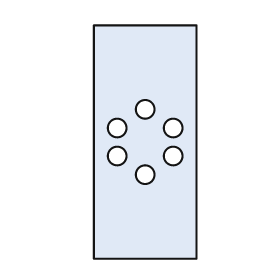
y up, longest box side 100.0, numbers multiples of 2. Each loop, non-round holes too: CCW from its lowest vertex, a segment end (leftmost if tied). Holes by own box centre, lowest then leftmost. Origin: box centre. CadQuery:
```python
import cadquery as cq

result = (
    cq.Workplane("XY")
    .moveTo(-22.0, -50.0)
    .lineTo(22.0, -50.0)
    .lineTo(22.0, 50.0)
    .lineTo(-22.0, 50.0)
    .close()
    .moveTo(0.0, -14.0)
    .circle(4.0)
    .moveTo(-12.0, -6.0)
    .circle(4.0)
    .moveTo(12.0, -6.0)
    .circle(4.0)
    .moveTo(-12.0, 6.0)
    .circle(4.0)
    .moveTo(12.0, 6.0)
    .circle(4.0)
    .moveTo(0.0, 14.0)
    .circle(4.0)
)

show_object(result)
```